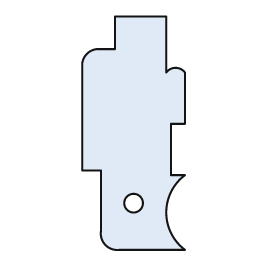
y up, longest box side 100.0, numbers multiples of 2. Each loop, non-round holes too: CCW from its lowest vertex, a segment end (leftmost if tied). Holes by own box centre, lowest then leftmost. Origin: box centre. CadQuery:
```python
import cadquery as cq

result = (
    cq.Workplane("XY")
    .moveTo(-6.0, -50.0)
    .lineTo(22.0, -50.0)
    .threePointArc((14.0, -34.0), (22.0, -18.0))
    .lineTo(16.0, -18.0)
    .lineTo(16.0, 4.0)
    .lineTo(22.0, 4.0)
    .lineTo(22.0, 26.0)
    .threePointArc((18.0, 28.0), (14.0, 26.0))
    .lineTo(14.0, 50.0)
    .lineTo(-8.0, 50.0)
    .lineTo(-8.0, 36.0)
    .lineTo(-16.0, 36.0)
    .threePointArc((-20.0, 34.0), (-22.0, 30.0))
    .lineTo(-22.0, -16.0)
    .lineTo(-14.0, -16.0)
    .lineTo(-14.0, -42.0)
    .threePointArc((-12.0, -48.0), (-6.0, -50.0))
    .close()
    .moveTo(0.0, -30.0)
    .circle(4.0)
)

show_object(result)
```